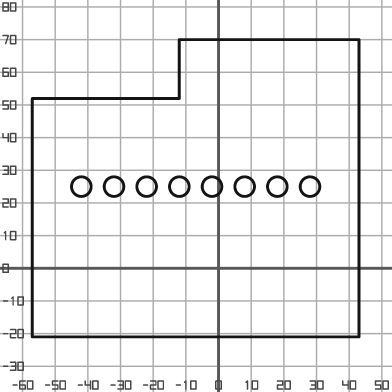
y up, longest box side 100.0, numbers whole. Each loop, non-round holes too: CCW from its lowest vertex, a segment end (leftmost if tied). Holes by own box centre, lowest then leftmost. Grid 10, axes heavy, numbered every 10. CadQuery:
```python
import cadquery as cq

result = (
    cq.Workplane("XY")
    .moveTo(-57.0, -21.0)
    .lineTo(43.0, -21.0)
    .lineTo(43.0, 70.0)
    .lineTo(-12.0, 70.0)
    .lineTo(-12.0, 52.0)
    .lineTo(-57.0, 52.0)
    .close()
    .moveTo(-42.0, 25.0)
    .circle(3.0)
    .moveTo(-32.0, 25.0)
    .circle(3.0)
    .moveTo(-22.0, 25.0)
    .circle(3.0)
    .moveTo(-12.0, 25.0)
    .circle(3.0)
    .moveTo(-2.0, 25.0)
    .circle(3.0)
    .moveTo(8.0, 25.0)
    .circle(3.0)
    .moveTo(18.0, 25.0)
    .circle(3.0)
    .moveTo(28.0, 25.0)
    .circle(3.0)
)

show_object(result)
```